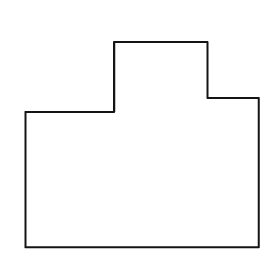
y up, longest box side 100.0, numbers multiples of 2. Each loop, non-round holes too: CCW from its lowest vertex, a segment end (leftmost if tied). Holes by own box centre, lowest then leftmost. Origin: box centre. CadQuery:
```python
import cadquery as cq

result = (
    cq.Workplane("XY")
    .moveTo(-50.0, -44.0)
    .lineTo(50.0, -44.0)
    .lineTo(50.0, 20.0)
    .lineTo(28.0, 20.0)
    .lineTo(28.0, 44.0)
    .lineTo(-12.0, 44.0)
    .lineTo(-12.0, 14.0)
    .lineTo(-50.0, 14.0)
    .close()
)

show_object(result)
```